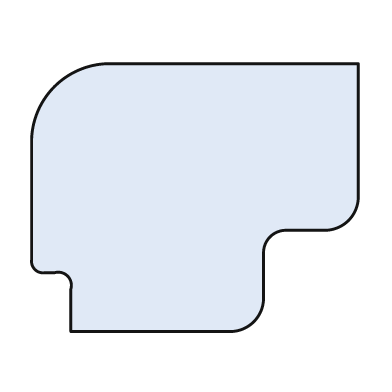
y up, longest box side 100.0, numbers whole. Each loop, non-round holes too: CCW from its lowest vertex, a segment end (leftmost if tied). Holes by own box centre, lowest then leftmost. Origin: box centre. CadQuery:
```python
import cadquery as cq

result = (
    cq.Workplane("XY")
    .moveTo(-38.0, -41.0)
    .lineTo(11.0, -41.0)
    .threePointArc((18.0, -38.0), (21.0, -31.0))
    .lineTo(21.0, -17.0)
    .threePointArc((23.0, -12.0), (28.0, -10.0))
    .lineTo(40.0, -10.0)
    .threePointArc((47.0, -7.0), (50.0, 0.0))
    .lineTo(50.0, 41.0)
    .lineTo(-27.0, 41.0)
    .threePointArc((-43.0, 34.0), (-50.0, 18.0))
    .lineTo(-50.0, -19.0)
    .threePointArc((-49.0, -22.0), (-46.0, -23.0))
    .lineTo(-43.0, -23.0)
    .threePointArc((-39.0, -24.0), (-38.0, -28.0))
    .close()
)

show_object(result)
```